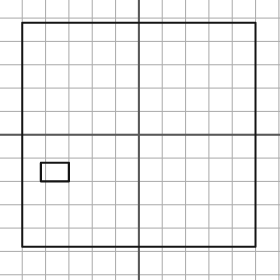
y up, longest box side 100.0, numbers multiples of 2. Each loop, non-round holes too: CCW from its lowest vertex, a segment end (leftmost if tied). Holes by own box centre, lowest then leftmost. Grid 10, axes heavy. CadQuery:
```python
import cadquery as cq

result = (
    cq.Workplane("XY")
    .moveTo(-50.0, -48.0)
    .lineTo(50.0, -48.0)
    .lineTo(50.0, 48.0)
    .lineTo(-50.0, 48.0)
    .close()
    .moveTo(-42.0, -20.0)
    .lineTo(-30.0, -20.0)
    .lineTo(-30.0, -12.0)
    .lineTo(-42.0, -12.0)
    .close()
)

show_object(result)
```